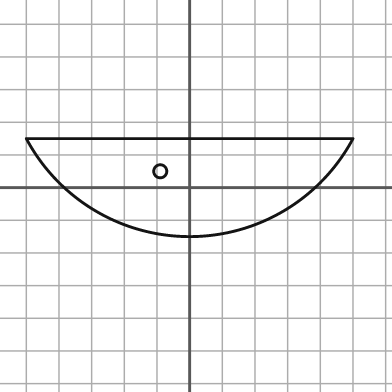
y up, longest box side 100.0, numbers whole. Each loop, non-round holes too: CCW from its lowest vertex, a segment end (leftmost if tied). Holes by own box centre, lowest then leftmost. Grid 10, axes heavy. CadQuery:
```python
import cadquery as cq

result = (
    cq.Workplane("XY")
    .moveTo(-50.0, 15.0)
    .threePointArc((0.0, -15.0), (50.0, 15.0))
    .close()
    .moveTo(-9.0, 5.0)
    .circle(2.0)
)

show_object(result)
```